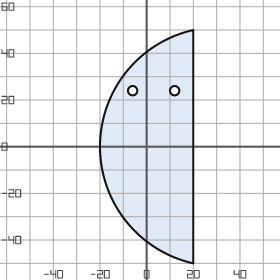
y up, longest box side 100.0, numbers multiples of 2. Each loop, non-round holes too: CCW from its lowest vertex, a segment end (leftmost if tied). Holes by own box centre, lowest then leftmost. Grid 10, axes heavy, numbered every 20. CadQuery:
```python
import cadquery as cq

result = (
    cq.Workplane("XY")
    .moveTo(20.0, -50.0)
    .lineTo(20.0, 50.0)
    .threePointArc((-20.0, 0.0), (20.0, -50.0))
    .close()
    .moveTo(-6.0, 24.0)
    .circle(2.0)
    .moveTo(12.0, 24.0)
    .circle(2.0)
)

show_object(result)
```